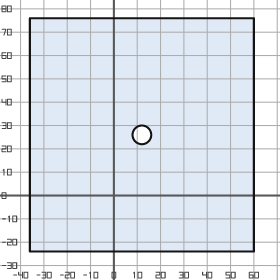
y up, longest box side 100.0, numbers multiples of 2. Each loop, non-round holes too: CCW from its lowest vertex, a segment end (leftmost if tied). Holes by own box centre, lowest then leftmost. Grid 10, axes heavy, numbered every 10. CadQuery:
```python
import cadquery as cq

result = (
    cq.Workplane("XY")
    .moveTo(-36.0, -24.0)
    .lineTo(60.0, -24.0)
    .lineTo(60.0, 76.0)
    .lineTo(-36.0, 76.0)
    .close()
    .moveTo(12.0, 26.0)
    .circle(4.0)
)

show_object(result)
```